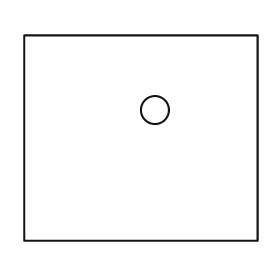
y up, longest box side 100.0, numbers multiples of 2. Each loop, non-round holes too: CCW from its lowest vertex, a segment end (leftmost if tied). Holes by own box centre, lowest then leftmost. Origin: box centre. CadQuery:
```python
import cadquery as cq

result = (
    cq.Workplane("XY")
    .moveTo(-50.0, -44.0)
    .lineTo(50.0, -44.0)
    .lineTo(50.0, 44.0)
    .lineTo(-50.0, 44.0)
    .close()
    .moveTo(6.0, 12.0)
    .circle(6.0)
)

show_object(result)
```